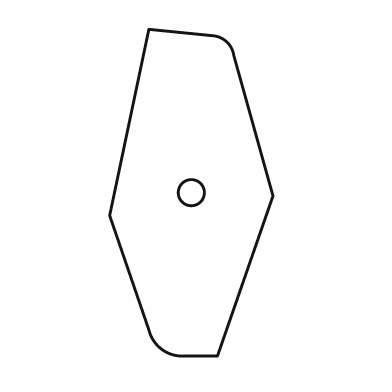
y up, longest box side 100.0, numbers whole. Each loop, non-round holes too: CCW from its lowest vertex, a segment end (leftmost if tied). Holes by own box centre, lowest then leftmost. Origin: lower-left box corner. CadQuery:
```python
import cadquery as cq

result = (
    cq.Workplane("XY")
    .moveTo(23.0, 0.0)
    .lineTo(33.0, 0.0)
    .lineTo(50.0, 49.0)
    .lineTo(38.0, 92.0)
    .threePointArc((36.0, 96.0), (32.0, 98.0))
    .lineTo(12.0, 100.0)
    .lineTo(0.0, 43.0)
    .lineTo(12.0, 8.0)
    .threePointArc((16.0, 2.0), (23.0, 0.0))
    .close()
    .moveTo(25.0, 50.0)
    .circle(4.0)
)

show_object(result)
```